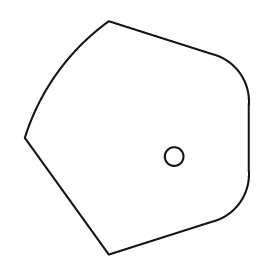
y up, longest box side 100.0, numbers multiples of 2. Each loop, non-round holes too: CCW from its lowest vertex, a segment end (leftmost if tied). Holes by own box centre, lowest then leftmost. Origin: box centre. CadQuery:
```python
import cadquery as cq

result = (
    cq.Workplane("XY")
    .moveTo(-12.0, -50.0)
    .lineTo(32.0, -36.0)
    .threePointArc((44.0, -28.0), (48.0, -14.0))
    .lineTo(48.0, 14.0)
    .threePointArc((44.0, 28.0), (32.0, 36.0))
    .lineTo(-12.0, 50.0)
    .threePointArc((-34.0, 28.0), (-48.0, 0.0))
    .close()
    .moveTo(16.0, -8.0)
    .circle(4.0)
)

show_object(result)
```